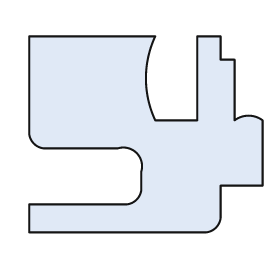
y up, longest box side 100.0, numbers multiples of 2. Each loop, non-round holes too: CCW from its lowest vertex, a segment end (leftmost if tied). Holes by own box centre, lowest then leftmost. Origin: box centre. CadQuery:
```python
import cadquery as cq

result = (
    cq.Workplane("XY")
    .moveTo(-50.0, -42.0)
    .lineTo(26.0, -42.0)
    .threePointArc((30.0, -40.0), (32.0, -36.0))
    .lineTo(32.0, -22.0)
    .lineTo(50.0, -22.0)
    .lineTo(50.0, 6.0)
    .threePointArc((44.0, 8.0), (38.0, 6.0))
    .lineTo(38.0, 32.0)
    .lineTo(32.0, 32.0)
    .lineTo(32.0, 42.0)
    .lineTo(22.0, 42.0)
    .lineTo(22.0, 6.0)
    .lineTo(4.0, 6.0)
    .threePointArc((0.0, 24.0), (4.0, 42.0))
    .lineTo(-50.0, 42.0)
    .lineTo(-50.0, 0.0)
    .threePointArc((-48.0, -4.0), (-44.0, -6.0))
    .lineTo(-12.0, -6.0)
    .threePointArc((-4.0, -8.0), (-2.0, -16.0))
    .lineTo(-2.0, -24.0)
    .threePointArc((-4.0, -28.0), (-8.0, -30.0))
    .lineTo(-50.0, -30.0)
    .close()
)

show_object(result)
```